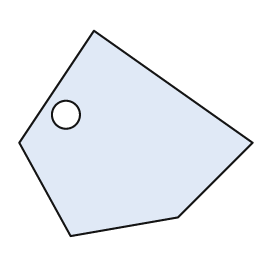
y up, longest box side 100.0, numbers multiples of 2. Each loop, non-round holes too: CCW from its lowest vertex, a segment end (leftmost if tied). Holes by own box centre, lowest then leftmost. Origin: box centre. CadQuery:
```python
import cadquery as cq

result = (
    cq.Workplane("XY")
    .moveTo(-28.0, -44.0)
    .lineTo(18.0, -36.0)
    .lineTo(50.0, -4.0)
    .lineTo(-18.0, 44.0)
    .lineTo(-50.0, -4.0)
    .close()
    .moveTo(-30.0, 8.0)
    .circle(6.0)
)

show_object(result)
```